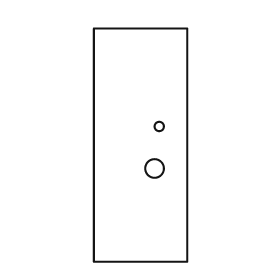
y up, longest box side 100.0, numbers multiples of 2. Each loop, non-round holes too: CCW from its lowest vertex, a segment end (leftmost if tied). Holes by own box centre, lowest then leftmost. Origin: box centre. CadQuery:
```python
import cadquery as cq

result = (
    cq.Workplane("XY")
    .moveTo(-20.0, -50.0)
    .lineTo(20.0, -50.0)
    .lineTo(20.0, 50.0)
    .lineTo(-20.0, 50.0)
    .close()
    .moveTo(6.0, -10.0)
    .circle(4.0)
    .moveTo(8.0, 8.0)
    .circle(2.0)
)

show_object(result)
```